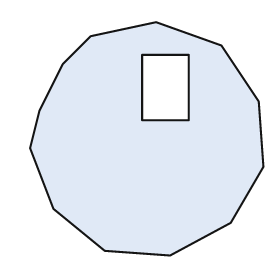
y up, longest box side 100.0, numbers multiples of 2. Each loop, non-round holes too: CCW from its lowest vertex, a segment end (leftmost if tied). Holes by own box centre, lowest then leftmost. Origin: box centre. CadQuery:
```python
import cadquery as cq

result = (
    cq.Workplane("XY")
    .moveTo(10.0, -50.0)
    .lineTo(36.0, -36.0)
    .lineTo(50.0, -12.0)
    .lineTo(48.0, 16.0)
    .lineTo(32.0, 40.0)
    .lineTo(4.0, 50.0)
    .lineTo(-24.0, 44.0)
    .lineTo(-36.0, 32.0)
    .lineTo(-46.0, 12.0)
    .lineTo(-50.0, -4.0)
    .lineTo(-40.0, -30.0)
    .lineTo(-18.0, -48.0)
    .close()
    .moveTo(-2.0, 8.0)
    .lineTo(18.0, 8.0)
    .lineTo(18.0, 36.0)
    .lineTo(-2.0, 36.0)
    .close()
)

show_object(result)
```